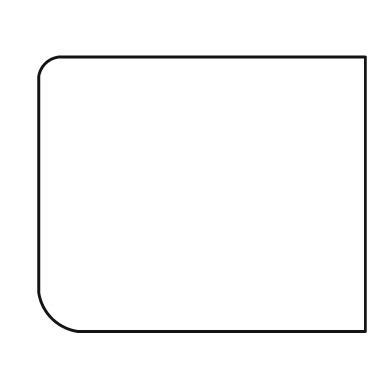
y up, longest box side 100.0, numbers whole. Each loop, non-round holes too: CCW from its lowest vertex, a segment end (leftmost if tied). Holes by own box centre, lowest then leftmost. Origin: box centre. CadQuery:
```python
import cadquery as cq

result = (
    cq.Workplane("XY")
    .moveTo(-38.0, -42.0)
    .lineTo(50.0, -42.0)
    .lineTo(50.0, 42.0)
    .lineTo(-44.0, 42.0)
    .threePointArc((-48.0, 40.0), (-50.0, 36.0))
    .lineTo(-50.0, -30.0)
    .threePointArc((-46.0, -38.0), (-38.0, -42.0))
    .close()
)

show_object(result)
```